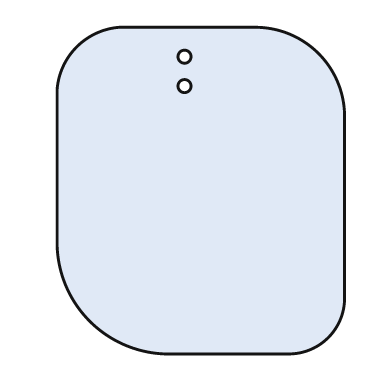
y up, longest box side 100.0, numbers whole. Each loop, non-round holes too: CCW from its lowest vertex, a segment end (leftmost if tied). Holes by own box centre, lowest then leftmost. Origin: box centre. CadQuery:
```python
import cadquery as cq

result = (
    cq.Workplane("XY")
    .moveTo(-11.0, -50.0)
    .lineTo(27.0, -50.0)
    .threePointArc((39.0, -45.0), (44.0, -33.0))
    .lineTo(44.0, 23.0)
    .threePointArc((36.0, 42.0), (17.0, 50.0))
    .lineTo(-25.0, 50.0)
    .threePointArc((-38.0, 44.0), (-44.0, 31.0))
    .lineTo(-44.0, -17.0)
    .threePointArc((-34.0, -40.0), (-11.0, -50.0))
    .close()
    .moveTo(-5.0, 32.0)
    .circle(2.0)
    .moveTo(-5.0, 41.0)
    .circle(2.0)
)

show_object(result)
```